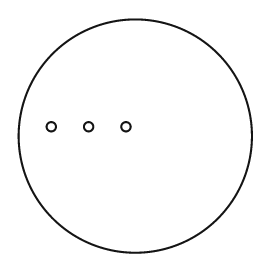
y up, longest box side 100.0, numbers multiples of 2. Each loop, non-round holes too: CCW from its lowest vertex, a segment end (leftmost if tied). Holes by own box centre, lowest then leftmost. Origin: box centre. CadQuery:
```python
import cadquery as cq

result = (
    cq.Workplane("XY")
    .moveTo(0.0, 0.0)
    .circle(50.0)
    .moveTo(-36.0, 4.0)
    .circle(2.0)
    .moveTo(-20.0, 4.0)
    .circle(2.0)
    .moveTo(-4.0, 4.0)
    .circle(2.0)
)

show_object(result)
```